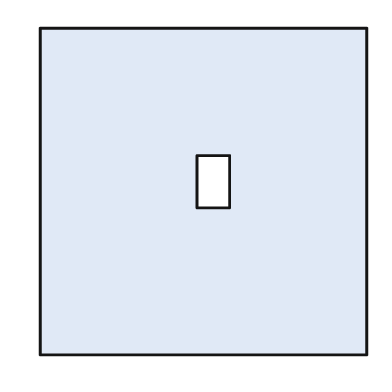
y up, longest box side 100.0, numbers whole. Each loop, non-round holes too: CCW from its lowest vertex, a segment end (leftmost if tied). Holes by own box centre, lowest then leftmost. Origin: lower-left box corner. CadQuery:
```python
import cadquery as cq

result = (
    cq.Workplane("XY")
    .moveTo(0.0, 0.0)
    .lineTo(100.0, 0.0)
    .lineTo(100.0, 100.0)
    .lineTo(0.0, 100.0)
    .close()
    .moveTo(48.0, 45.0)
    .lineTo(58.0, 45.0)
    .lineTo(58.0, 61.0)
    .lineTo(48.0, 61.0)
    .close()
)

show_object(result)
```